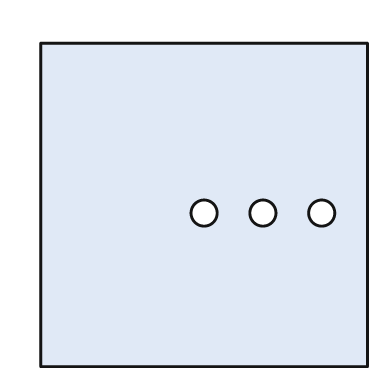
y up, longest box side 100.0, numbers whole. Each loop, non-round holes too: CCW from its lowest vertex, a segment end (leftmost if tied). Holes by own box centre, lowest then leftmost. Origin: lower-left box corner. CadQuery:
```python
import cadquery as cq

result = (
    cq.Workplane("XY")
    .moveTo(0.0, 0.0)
    .lineTo(100.0, 0.0)
    .lineTo(100.0, 99.0)
    .lineTo(0.0, 99.0)
    .close()
    .moveTo(50.0, 47.0)
    .circle(4.0)
    .moveTo(68.0, 47.0)
    .circle(4.0)
    .moveTo(86.0, 47.0)
    .circle(4.0)
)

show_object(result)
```